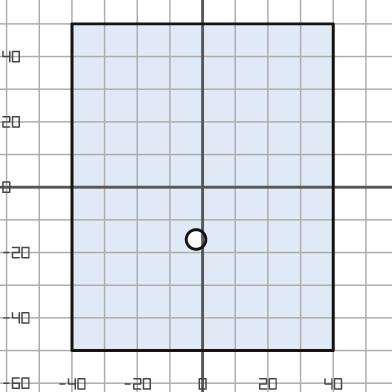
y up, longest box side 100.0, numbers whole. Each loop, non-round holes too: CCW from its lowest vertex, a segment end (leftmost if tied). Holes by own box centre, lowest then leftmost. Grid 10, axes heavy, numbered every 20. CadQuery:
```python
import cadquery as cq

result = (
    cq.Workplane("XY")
    .moveTo(-40.0, -50.0)
    .lineTo(40.0, -50.0)
    .lineTo(40.0, 50.0)
    .lineTo(-40.0, 50.0)
    .close()
    .moveTo(-2.0, -16.0)
    .circle(3.0)
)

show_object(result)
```